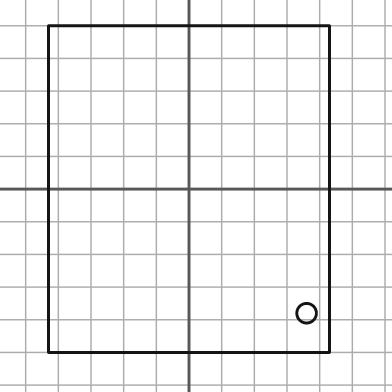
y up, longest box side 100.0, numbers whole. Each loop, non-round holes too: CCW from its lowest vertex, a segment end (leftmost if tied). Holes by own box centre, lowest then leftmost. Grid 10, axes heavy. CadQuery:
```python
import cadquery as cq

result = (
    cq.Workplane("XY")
    .moveTo(-43.0, -50.0)
    .lineTo(43.0, -50.0)
    .lineTo(43.0, 50.0)
    .lineTo(-43.0, 50.0)
    .close()
    .moveTo(36.0, -38.0)
    .circle(3.0)
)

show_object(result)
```